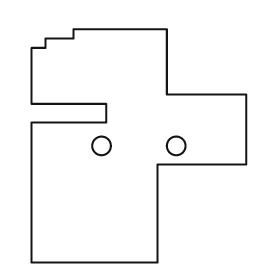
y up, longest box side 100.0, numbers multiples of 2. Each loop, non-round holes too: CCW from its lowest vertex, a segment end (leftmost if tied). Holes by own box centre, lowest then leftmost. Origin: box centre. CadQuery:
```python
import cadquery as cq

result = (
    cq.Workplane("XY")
    .moveTo(-46.0, -50.0)
    .lineTo(8.0, -50.0)
    .lineTo(8.0, -8.0)
    .lineTo(46.0, -8.0)
    .lineTo(46.0, 22.0)
    .lineTo(12.0, 22.0)
    .lineTo(12.0, 50.0)
    .lineTo(-28.0, 50.0)
    .lineTo(-28.0, 46.0)
    .lineTo(-40.0, 46.0)
    .lineTo(-40.0, 42.0)
    .lineTo(-46.0, 42.0)
    .lineTo(-46.0, 18.0)
    .lineTo(-14.0, 18.0)
    .lineTo(-14.0, 10.0)
    .lineTo(-46.0, 10.0)
    .close()
    .moveTo(-16.0, 0.0)
    .circle(4.0)
    .moveTo(16.0, 0.0)
    .circle(4.0)
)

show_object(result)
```